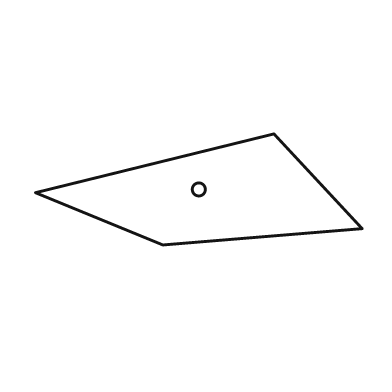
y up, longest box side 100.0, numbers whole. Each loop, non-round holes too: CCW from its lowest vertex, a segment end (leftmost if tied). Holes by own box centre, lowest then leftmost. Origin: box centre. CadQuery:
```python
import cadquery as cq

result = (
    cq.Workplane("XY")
    .moveTo(-11.0, -17.0)
    .lineTo(50.0, -12.0)
    .lineTo(23.0, 17.0)
    .lineTo(-50.0, -1.0)
    .close()
    .moveTo(0.0, 0.0)
    .circle(2.0)
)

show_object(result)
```